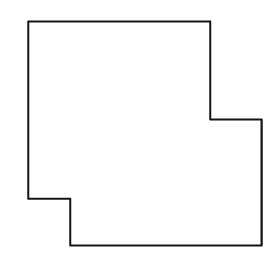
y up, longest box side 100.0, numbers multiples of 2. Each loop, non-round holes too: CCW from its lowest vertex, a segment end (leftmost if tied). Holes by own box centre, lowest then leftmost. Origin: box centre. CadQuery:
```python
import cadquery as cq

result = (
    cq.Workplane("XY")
    .moveTo(-32.0, -48.0)
    .lineTo(50.0, -48.0)
    .lineTo(50.0, 6.0)
    .lineTo(28.0, 6.0)
    .lineTo(28.0, 48.0)
    .lineTo(-50.0, 48.0)
    .lineTo(-50.0, -28.0)
    .lineTo(-32.0, -28.0)
    .close()
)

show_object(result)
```